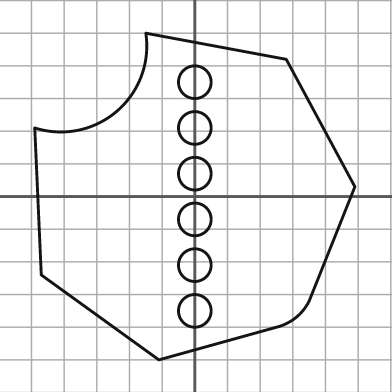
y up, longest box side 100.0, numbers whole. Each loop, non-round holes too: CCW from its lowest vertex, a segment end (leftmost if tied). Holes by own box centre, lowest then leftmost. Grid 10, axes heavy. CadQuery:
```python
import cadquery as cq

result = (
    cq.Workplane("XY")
    .moveTo(-11.0, -50.0)
    .lineTo(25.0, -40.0)
    .threePointArc((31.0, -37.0), (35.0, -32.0))
    .lineTo(49.0, 3.0)
    .lineTo(28.0, 42.0)
    .lineTo(-15.0, 50.0)
    .threePointArc((-24.0, 26.0), (-49.0, 21.0))
    .lineTo(-47.0, -24.0)
    .close()
    .moveTo(0.0, -35.0)
    .circle(5.0)
    .moveTo(0.0, -21.0)
    .circle(5.0)
    .moveTo(0.0, -7.0)
    .circle(5.0)
    .moveTo(0.0, 7.0)
    .circle(5.0)
    .moveTo(0.0, 21.0)
    .circle(5.0)
    .moveTo(0.0, 35.0)
    .circle(5.0)
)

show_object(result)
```